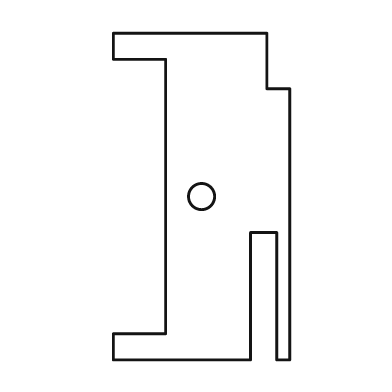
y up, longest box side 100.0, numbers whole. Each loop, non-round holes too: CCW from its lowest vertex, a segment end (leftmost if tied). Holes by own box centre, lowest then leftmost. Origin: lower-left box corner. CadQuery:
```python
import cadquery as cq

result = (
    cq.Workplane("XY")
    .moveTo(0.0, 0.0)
    .lineTo(42.0, 0.0)
    .lineTo(42.0, 39.0)
    .lineTo(50.0, 39.0)
    .lineTo(50.0, 0.0)
    .lineTo(54.0, 0.0)
    .lineTo(54.0, 83.0)
    .lineTo(47.0, 83.0)
    .lineTo(47.0, 100.0)
    .lineTo(0.0, 100.0)
    .lineTo(0.0, 92.0)
    .lineTo(16.0, 92.0)
    .lineTo(16.0, 8.0)
    .lineTo(0.0, 8.0)
    .close()
    .moveTo(27.0, 50.0)
    .circle(4.0)
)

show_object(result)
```